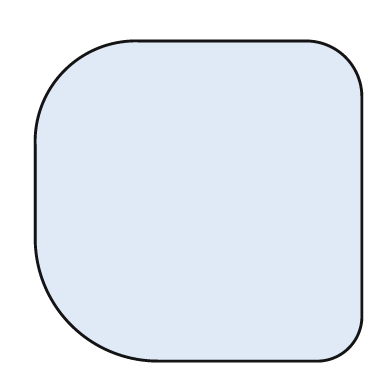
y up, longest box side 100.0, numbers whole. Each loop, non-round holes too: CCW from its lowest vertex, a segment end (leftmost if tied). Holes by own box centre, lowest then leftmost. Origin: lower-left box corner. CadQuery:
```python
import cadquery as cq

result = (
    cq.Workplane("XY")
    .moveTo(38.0, 0.0)
    .lineTo(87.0, 0.0)
    .threePointArc((96.0, 4.0), (100.0, 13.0))
    .lineTo(100.0, 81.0)
    .threePointArc((95.0, 93.0), (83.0, 98.0))
    .lineTo(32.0, 98.0)
    .threePointArc((9.0, 89.0), (0.0, 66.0))
    .lineTo(0.0, 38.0)
    .threePointArc((11.0, 11.0), (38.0, 0.0))
    .close()
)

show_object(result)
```